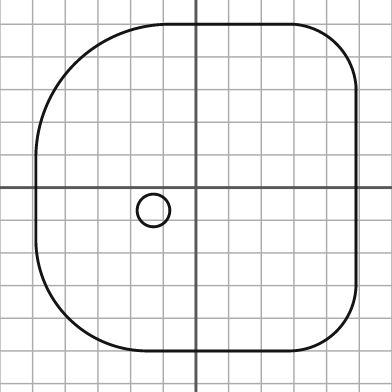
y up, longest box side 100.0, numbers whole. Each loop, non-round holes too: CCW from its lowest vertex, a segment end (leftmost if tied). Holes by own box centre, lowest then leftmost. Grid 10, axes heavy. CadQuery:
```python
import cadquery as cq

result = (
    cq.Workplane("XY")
    .moveTo(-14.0, -50.0)
    .lineTo(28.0, -50.0)
    .threePointArc((43.0, -44.0), (49.0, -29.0))
    .lineTo(49.0, 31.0)
    .threePointArc((43.0, 44.0), (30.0, 50.0))
    .lineTo(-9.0, 50.0)
    .threePointArc((-37.0, 38.0), (-49.0, 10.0))
    .lineTo(-49.0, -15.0)
    .threePointArc((-39.0, -40.0), (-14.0, -50.0))
    .close()
    .moveTo(-13.0, -7.0)
    .circle(5.0)
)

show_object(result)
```